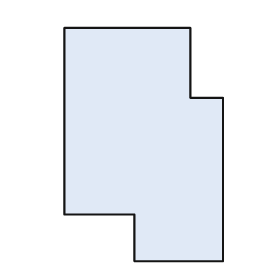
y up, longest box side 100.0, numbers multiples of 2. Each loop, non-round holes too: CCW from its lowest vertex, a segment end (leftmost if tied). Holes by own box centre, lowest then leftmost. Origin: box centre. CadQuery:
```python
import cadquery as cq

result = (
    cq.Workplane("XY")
    .moveTo(-4.0, -50.0)
    .lineTo(34.0, -50.0)
    .lineTo(34.0, 20.0)
    .lineTo(20.0, 20.0)
    .lineTo(20.0, 50.0)
    .lineTo(-34.0, 50.0)
    .lineTo(-34.0, -30.0)
    .lineTo(-4.0, -30.0)
    .close()
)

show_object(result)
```